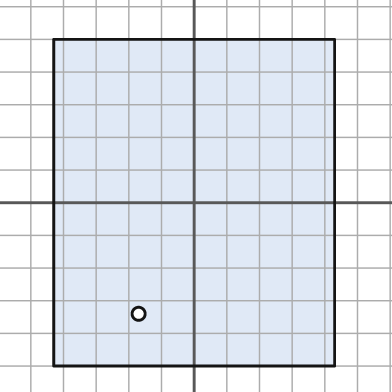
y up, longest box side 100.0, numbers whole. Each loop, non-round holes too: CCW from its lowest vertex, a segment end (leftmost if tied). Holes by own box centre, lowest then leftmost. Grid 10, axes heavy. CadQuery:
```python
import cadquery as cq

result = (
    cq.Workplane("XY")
    .moveTo(-43.0, -50.0)
    .lineTo(43.0, -50.0)
    .lineTo(43.0, 50.0)
    .lineTo(-43.0, 50.0)
    .close()
    .moveTo(-17.0, -34.0)
    .circle(2.0)
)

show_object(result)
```